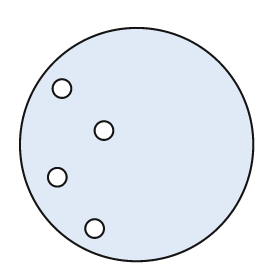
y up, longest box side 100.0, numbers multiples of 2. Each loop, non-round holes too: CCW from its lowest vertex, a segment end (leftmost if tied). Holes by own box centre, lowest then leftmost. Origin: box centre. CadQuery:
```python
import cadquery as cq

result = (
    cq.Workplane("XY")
    .moveTo(0.0, 0.0)
    .circle(50.0)
    .moveTo(-18.0, -36.0)
    .circle(4.0)
    .moveTo(-34.0, -14.0)
    .circle(4.0)
    .moveTo(-14.0, 6.0)
    .circle(4.0)
    .moveTo(-32.0, 24.0)
    .circle(4.0)
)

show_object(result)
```